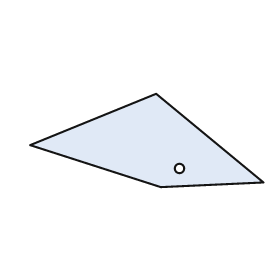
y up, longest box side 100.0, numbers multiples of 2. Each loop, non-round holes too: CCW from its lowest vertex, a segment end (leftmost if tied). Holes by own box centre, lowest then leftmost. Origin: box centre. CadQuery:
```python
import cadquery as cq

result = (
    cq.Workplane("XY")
    .moveTo(6.0, -20.0)
    .lineTo(50.0, -18.0)
    .lineTo(4.0, 20.0)
    .lineTo(-50.0, -2.0)
    .close()
    .moveTo(14.0, -12.0)
    .circle(2.0)
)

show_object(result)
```